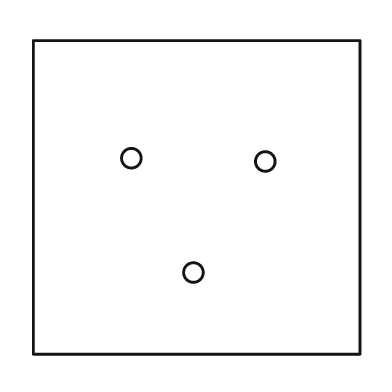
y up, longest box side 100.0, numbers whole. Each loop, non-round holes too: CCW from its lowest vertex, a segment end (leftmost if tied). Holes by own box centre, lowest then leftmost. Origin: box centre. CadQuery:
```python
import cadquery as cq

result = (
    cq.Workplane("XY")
    .moveTo(-50.0, -48.0)
    .lineTo(50.0, -48.0)
    .lineTo(50.0, 48.0)
    .lineTo(-50.0, 48.0)
    .close()
    .moveTo(-1.0, -23.0)
    .circle(3.0)
    .moveTo(21.0, 11.0)
    .circle(3.0)
    .moveTo(-20.0, 12.0)
    .circle(3.0)
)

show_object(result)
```